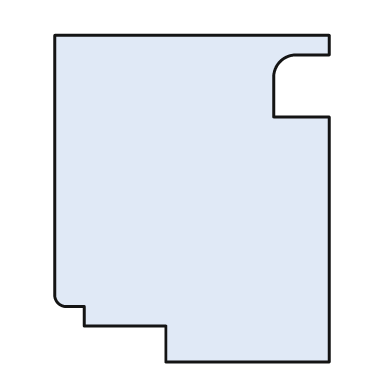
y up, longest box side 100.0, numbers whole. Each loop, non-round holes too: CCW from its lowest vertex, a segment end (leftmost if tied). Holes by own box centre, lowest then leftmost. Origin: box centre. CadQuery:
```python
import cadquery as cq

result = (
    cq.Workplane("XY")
    .moveTo(-8.0, -50.0)
    .lineTo(42.0, -50.0)
    .lineTo(42.0, 25.0)
    .lineTo(25.0, 25.0)
    .lineTo(25.0, 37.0)
    .threePointArc((27.0, 42.0), (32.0, 44.0))
    .lineTo(42.0, 44.0)
    .lineTo(42.0, 50.0)
    .lineTo(-42.0, 50.0)
    .lineTo(-42.0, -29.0)
    .threePointArc((-41.0, -32.0), (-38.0, -33.0))
    .lineTo(-33.0, -33.0)
    .lineTo(-33.0, -39.0)
    .lineTo(-8.0, -39.0)
    .close()
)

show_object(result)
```